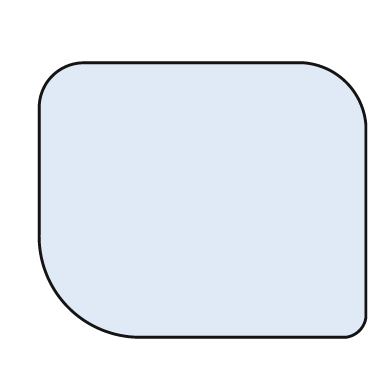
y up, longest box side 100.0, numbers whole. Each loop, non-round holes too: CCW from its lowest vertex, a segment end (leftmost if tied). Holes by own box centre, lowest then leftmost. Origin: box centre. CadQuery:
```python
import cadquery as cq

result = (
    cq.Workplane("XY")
    .moveTo(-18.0, -42.0)
    .lineTo(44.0, -42.0)
    .threePointArc((48.0, -40.0), (50.0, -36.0))
    .lineTo(50.0, 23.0)
    .threePointArc((44.0, 36.0), (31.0, 42.0))
    .lineTo(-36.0, 42.0)
    .threePointArc((-46.0, 38.0), (-50.0, 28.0))
    .lineTo(-50.0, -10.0)
    .threePointArc((-41.0, -33.0), (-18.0, -42.0))
    .close()
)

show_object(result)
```